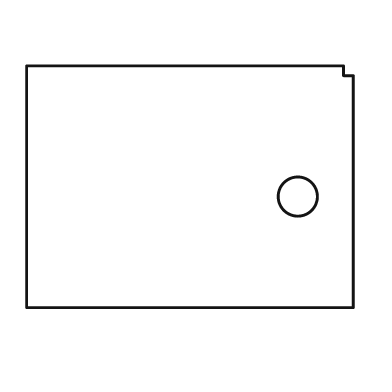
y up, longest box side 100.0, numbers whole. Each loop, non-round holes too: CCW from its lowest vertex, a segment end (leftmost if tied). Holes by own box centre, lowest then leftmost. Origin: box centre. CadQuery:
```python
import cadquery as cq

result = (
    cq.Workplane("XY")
    .moveTo(-50.0, -37.0)
    .lineTo(50.0, -37.0)
    .lineTo(50.0, 34.0)
    .lineTo(47.0, 34.0)
    .lineTo(47.0, 37.0)
    .lineTo(-50.0, 37.0)
    .close()
    .moveTo(33.0, -3.0)
    .circle(6.0)
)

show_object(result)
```